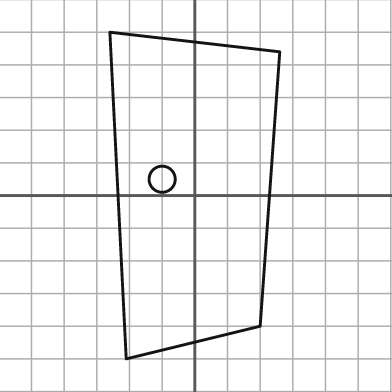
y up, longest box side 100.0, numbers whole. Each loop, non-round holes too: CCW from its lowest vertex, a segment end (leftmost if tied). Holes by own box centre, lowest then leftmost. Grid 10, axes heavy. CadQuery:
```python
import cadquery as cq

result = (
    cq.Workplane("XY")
    .moveTo(-21.0, -50.0)
    .lineTo(20.0, -40.0)
    .lineTo(26.0, 44.0)
    .lineTo(-26.0, 50.0)
    .close()
    .moveTo(-10.0, 5.0)
    .circle(4.0)
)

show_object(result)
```